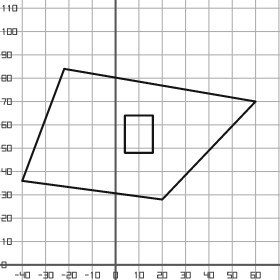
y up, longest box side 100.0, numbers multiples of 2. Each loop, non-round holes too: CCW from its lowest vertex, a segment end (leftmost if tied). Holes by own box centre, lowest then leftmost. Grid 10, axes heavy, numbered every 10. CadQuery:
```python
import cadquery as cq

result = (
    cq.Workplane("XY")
    .moveTo(20.0, 28.0)
    .lineTo(60.0, 70.0)
    .lineTo(-22.0, 84.0)
    .lineTo(-40.0, 36.0)
    .close()
    .moveTo(4.0, 48.0)
    .lineTo(16.0, 48.0)
    .lineTo(16.0, 64.0)
    .lineTo(4.0, 64.0)
    .close()
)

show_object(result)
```